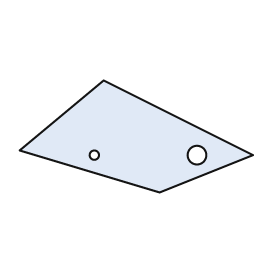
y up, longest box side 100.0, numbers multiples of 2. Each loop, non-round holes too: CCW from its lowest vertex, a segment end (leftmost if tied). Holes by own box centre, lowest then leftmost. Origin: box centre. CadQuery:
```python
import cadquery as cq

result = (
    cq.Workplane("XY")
    .moveTo(10.0, -24.0)
    .lineTo(50.0, -8.0)
    .lineTo(-14.0, 24.0)
    .lineTo(-50.0, -6.0)
    .close()
    .moveTo(-18.0, -8.0)
    .circle(2.0)
    .moveTo(26.0, -8.0)
    .circle(4.0)
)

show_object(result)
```